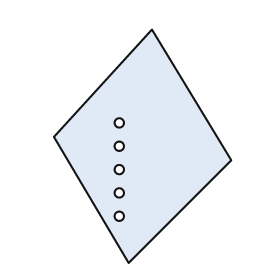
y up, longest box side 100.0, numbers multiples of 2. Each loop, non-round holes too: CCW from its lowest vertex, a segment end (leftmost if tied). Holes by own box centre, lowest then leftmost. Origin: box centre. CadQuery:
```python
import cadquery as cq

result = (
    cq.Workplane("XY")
    .moveTo(-6.0, -50.0)
    .lineTo(38.0, -6.0)
    .lineTo(4.0, 50.0)
    .lineTo(-38.0, 4.0)
    .close()
    .moveTo(-10.0, -30.0)
    .circle(2.0)
    .moveTo(-10.0, -20.0)
    .circle(2.0)
    .moveTo(-10.0, -10.0)
    .circle(2.0)
    .moveTo(-10.0, 0.0)
    .circle(2.0)
    .moveTo(-10.0, 10.0)
    .circle(2.0)
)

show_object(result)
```